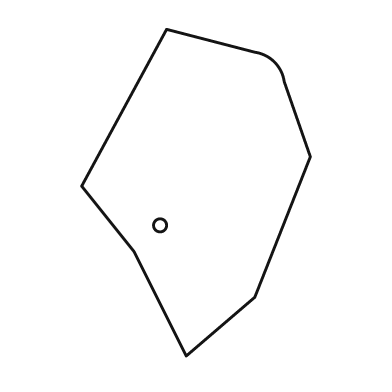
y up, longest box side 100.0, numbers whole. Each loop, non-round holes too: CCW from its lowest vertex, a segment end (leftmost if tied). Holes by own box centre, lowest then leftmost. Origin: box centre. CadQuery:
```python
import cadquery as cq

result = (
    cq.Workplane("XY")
    .moveTo(-3.0, -50.0)
    .lineTo(18.0, -32.0)
    .lineTo(35.0, 11.0)
    .lineTo(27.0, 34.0)
    .threePointArc((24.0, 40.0), (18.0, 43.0))
    .lineTo(-9.0, 50.0)
    .lineTo(-35.0, 2.0)
    .lineTo(-19.0, -18.0)
    .close()
    .moveTo(-11.0, -10.0)
    .circle(2.0)
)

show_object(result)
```